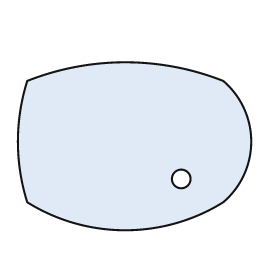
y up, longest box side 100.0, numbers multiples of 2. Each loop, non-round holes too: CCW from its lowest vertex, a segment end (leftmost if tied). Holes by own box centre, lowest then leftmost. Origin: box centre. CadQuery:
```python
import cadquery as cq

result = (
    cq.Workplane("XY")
    .moveTo(-46.0, -24.0)
    .threePointArc((-4.0, -36.0), (38.0, -24.0))
    .threePointArc((50.0, 2.0), (38.0, 28.0))
    .threePointArc((-4.0, 36.0), (-46.0, 28.0))
    .threePointArc((-50.0, 2.0), (-46.0, -24.0))
    .close()
    .moveTo(20.0, -14.0)
    .circle(4.0)
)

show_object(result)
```